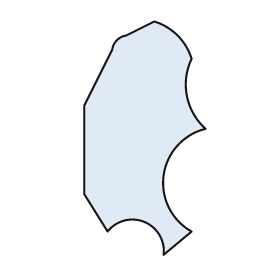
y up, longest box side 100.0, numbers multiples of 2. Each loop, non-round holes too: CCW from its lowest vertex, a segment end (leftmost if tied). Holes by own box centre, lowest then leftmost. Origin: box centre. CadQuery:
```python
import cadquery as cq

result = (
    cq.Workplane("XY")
    .moveTo(8.0, -50.0)
    .lineTo(20.0, -40.0)
    .threePointArc((8.0, -16.0), (26.0, 4.0))
    .threePointArc((18.0, 18.0), (20.0, 34.0))
    .threePointArc((14.0, 44.0), (4.0, 50.0))
    .lineTo(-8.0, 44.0)
    .threePointArc((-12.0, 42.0), (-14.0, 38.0))
    .lineTo(-26.0, 14.0)
    .lineTo(-26.0, -24.0)
    .lineTo(-16.0, -40.0)
    .threePointArc((0.0, -36.0), (8.0, -50.0))
    .close()
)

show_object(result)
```